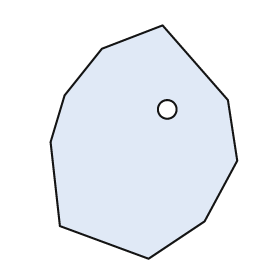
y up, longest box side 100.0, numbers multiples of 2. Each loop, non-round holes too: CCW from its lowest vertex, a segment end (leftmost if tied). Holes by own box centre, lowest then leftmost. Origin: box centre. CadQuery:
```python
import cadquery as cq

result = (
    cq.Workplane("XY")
    .moveTo(2.0, -50.0)
    .lineTo(26.0, -34.0)
    .lineTo(40.0, -8.0)
    .lineTo(36.0, 18.0)
    .lineTo(8.0, 50.0)
    .lineTo(-18.0, 40.0)
    .lineTo(-34.0, 20.0)
    .lineTo(-40.0, 0.0)
    .lineTo(-36.0, -36.0)
    .close()
    .moveTo(10.0, 14.0)
    .circle(4.0)
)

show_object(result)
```